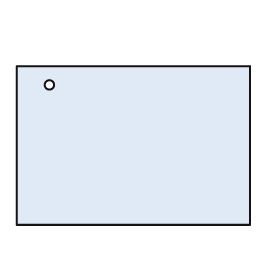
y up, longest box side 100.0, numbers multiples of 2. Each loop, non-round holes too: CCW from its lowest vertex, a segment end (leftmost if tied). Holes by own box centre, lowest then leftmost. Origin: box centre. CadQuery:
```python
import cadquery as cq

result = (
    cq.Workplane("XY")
    .moveTo(-50.0, -34.0)
    .lineTo(50.0, -34.0)
    .lineTo(50.0, 34.0)
    .lineTo(-50.0, 34.0)
    .close()
    .moveTo(-36.0, 26.0)
    .circle(2.0)
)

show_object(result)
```